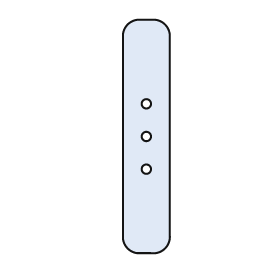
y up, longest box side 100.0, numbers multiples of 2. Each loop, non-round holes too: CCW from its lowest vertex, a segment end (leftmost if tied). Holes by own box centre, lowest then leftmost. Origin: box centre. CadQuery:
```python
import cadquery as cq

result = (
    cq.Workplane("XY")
    .moveTo(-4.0, -50.0)
    .lineTo(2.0, -50.0)
    .threePointArc((8.0, -48.0), (10.0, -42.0))
    .lineTo(10.0, 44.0)
    .threePointArc((8.0, 48.0), (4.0, 50.0))
    .lineTo(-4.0, 50.0)
    .threePointArc((-8.0, 48.0), (-10.0, 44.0))
    .lineTo(-10.0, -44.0)
    .threePointArc((-8.0, -48.0), (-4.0, -50.0))
    .close()
    .moveTo(0.0, -14.0)
    .circle(2.0)
    .moveTo(0.0, 0.0)
    .circle(2.0)
    .moveTo(0.0, 14.0)
    .circle(2.0)
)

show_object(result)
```